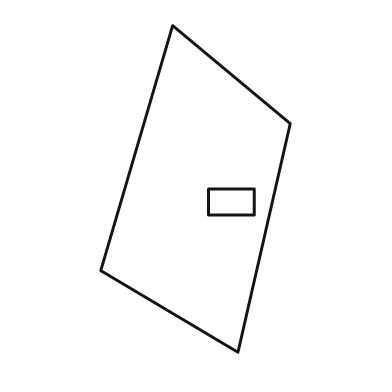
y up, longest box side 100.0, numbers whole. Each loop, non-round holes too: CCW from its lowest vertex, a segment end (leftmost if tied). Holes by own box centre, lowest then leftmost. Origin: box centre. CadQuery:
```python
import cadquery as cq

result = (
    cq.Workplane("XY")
    .moveTo(13.0, -50.0)
    .lineTo(29.0, 20.0)
    .lineTo(-7.0, 50.0)
    .lineTo(-29.0, -25.0)
    .close()
    .moveTo(4.0, -8.0)
    .lineTo(18.0, -8.0)
    .lineTo(18.0, 0.0)
    .lineTo(4.0, 0.0)
    .close()
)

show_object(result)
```